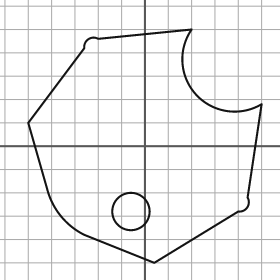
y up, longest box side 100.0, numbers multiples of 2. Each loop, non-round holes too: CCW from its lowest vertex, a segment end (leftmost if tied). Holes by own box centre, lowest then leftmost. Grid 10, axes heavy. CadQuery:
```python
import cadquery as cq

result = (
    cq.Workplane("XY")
    .moveTo(4.0, -50.0)
    .lineTo(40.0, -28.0)
    .threePointArc((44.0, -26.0), (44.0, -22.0))
    .lineTo(50.0, 18.0)
    .threePointArc((22.0, 22.0), (20.0, 50.0))
    .lineTo(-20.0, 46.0)
    .threePointArc((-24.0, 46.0), (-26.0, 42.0))
    .lineTo(-50.0, 10.0)
    .lineTo(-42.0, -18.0)
    .threePointArc((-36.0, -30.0), (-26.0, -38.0))
    .close()
    .moveTo(-6.0, -28.0)
    .circle(8.0)
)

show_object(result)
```